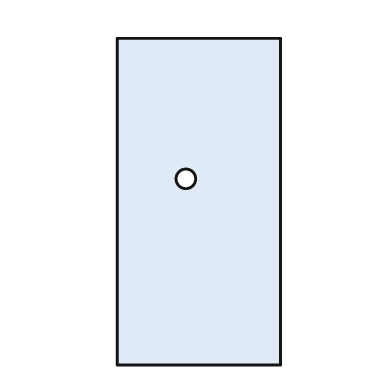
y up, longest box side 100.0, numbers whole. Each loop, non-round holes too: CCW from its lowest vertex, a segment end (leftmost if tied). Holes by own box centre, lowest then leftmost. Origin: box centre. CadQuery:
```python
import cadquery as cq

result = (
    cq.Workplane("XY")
    .moveTo(-25.0, -50.0)
    .lineTo(25.0, -50.0)
    .lineTo(25.0, 50.0)
    .lineTo(-25.0, 50.0)
    .close()
    .moveTo(-4.0, 7.0)
    .circle(3.0)
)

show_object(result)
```